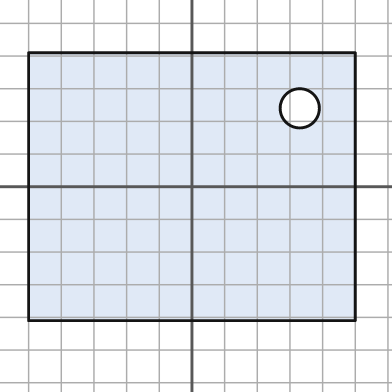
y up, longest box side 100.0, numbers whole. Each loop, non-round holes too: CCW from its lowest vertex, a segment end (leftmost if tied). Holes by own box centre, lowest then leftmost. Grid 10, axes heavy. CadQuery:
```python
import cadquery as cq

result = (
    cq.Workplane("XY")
    .moveTo(-50.0, -41.0)
    .lineTo(50.0, -41.0)
    .lineTo(50.0, 41.0)
    .lineTo(-50.0, 41.0)
    .close()
    .moveTo(33.0, 24.0)
    .circle(6.0)
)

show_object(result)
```